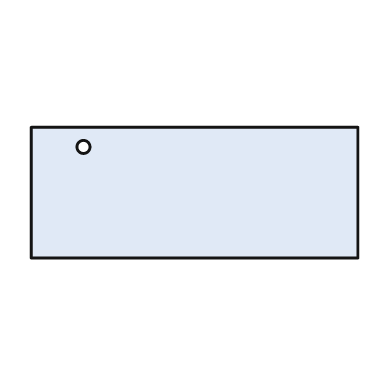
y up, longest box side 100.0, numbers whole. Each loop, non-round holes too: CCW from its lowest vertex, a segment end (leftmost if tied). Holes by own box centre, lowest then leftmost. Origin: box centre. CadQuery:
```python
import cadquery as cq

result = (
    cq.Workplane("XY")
    .moveTo(-50.0, -20.0)
    .lineTo(50.0, -20.0)
    .lineTo(50.0, 20.0)
    .lineTo(-50.0, 20.0)
    .close()
    .moveTo(-34.0, 14.0)
    .circle(2.0)
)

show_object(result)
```